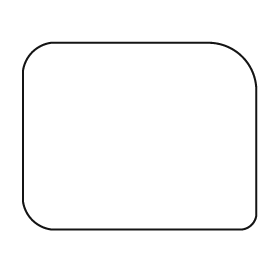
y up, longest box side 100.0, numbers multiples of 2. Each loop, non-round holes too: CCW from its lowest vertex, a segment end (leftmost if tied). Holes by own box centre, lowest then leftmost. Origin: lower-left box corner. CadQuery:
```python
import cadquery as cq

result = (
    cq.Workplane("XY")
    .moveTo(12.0, 0.0)
    .lineTo(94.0, 0.0)
    .threePointArc((98.0, 2.0), (100.0, 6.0))
    .lineTo(100.0, 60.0)
    .threePointArc((94.0, 74.0), (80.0, 80.0))
    .lineTo(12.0, 80.0)
    .threePointArc((4.0, 76.0), (0.0, 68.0))
    .lineTo(0.0, 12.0)
    .threePointArc((4.0, 4.0), (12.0, 0.0))
    .close()
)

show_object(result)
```